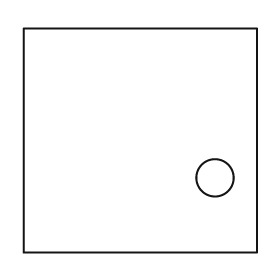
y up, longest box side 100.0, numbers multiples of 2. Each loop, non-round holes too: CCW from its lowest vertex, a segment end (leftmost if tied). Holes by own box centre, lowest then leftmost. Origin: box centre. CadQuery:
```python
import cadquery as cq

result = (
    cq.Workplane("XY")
    .moveTo(-50.0, -48.0)
    .lineTo(50.0, -48.0)
    .lineTo(50.0, 48.0)
    .lineTo(-50.0, 48.0)
    .close()
    .moveTo(32.0, -16.0)
    .circle(8.0)
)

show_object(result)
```